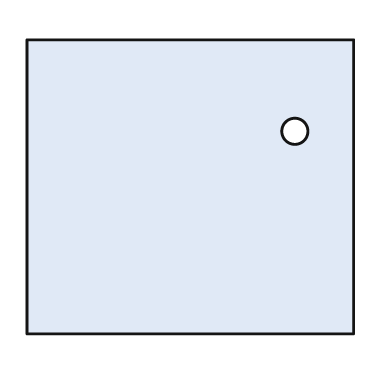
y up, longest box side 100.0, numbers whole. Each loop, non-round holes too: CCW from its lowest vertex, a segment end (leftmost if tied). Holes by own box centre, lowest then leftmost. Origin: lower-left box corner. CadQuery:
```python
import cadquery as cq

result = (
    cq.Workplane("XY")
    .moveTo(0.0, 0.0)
    .lineTo(100.0, 0.0)
    .lineTo(100.0, 90.0)
    .lineTo(0.0, 90.0)
    .close()
    .moveTo(82.0, 62.0)
    .circle(4.0)
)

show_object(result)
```